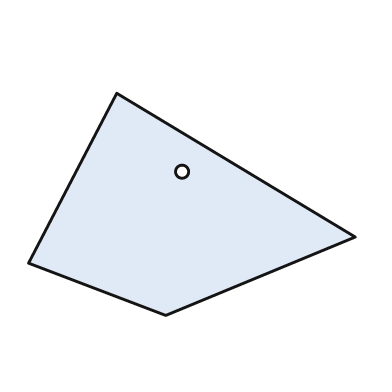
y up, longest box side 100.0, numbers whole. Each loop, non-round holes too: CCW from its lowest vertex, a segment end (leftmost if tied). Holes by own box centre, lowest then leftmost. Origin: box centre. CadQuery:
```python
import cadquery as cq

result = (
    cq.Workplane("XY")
    .moveTo(-8.0, -34.0)
    .lineTo(50.0, -10.0)
    .lineTo(-23.0, 34.0)
    .lineTo(-50.0, -18.0)
    .close()
    .moveTo(-3.0, 10.0)
    .circle(2.0)
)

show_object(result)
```